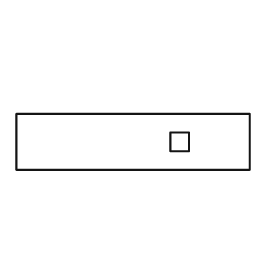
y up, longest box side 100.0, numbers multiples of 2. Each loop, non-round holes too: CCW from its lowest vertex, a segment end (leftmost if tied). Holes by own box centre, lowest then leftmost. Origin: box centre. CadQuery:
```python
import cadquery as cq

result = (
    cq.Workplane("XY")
    .moveTo(-50.0, -12.0)
    .lineTo(50.0, -12.0)
    .lineTo(50.0, 12.0)
    .lineTo(-50.0, 12.0)
    .close()
    .moveTo(16.0, -4.0)
    .lineTo(24.0, -4.0)
    .lineTo(24.0, 4.0)
    .lineTo(16.0, 4.0)
    .close()
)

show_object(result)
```